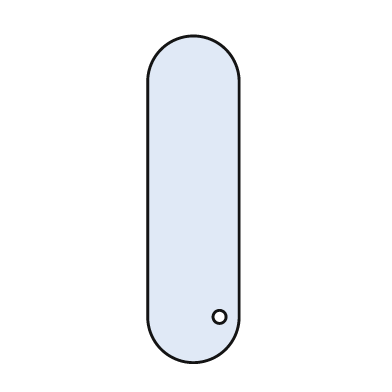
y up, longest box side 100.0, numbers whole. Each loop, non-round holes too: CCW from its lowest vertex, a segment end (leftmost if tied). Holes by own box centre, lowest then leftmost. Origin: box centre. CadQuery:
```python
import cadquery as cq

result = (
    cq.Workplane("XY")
    .moveTo(-14.0, -36.0)
    .threePointArc((0.0, -50.0), (14.0, -36.0))
    .lineTo(14.0, 36.0)
    .threePointArc((0.0, 50.0), (-14.0, 36.0))
    .close()
    .moveTo(8.0, -36.0)
    .circle(2.0)
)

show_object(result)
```